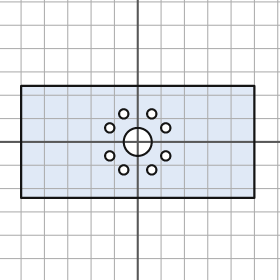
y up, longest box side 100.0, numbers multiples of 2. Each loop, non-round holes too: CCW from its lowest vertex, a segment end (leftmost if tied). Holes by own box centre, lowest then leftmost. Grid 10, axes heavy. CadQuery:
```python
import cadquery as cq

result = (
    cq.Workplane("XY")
    .moveTo(-50.0, -24.0)
    .lineTo(50.0, -24.0)
    .lineTo(50.0, 24.0)
    .lineTo(-50.0, 24.0)
    .close()
    .moveTo(-6.0, -12.0)
    .circle(2.0)
    .moveTo(6.0, -12.0)
    .circle(2.0)
    .moveTo(-12.0, -6.0)
    .circle(2.0)
    .moveTo(12.0, -6.0)
    .circle(2.0)
    .moveTo(0.0, 0.0)
    .circle(6.0)
    .moveTo(-12.0, 6.0)
    .circle(2.0)
    .moveTo(12.0, 6.0)
    .circle(2.0)
    .moveTo(-6.0, 12.0)
    .circle(2.0)
    .moveTo(6.0, 12.0)
    .circle(2.0)
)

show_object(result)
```